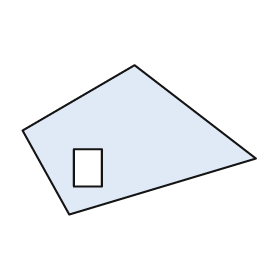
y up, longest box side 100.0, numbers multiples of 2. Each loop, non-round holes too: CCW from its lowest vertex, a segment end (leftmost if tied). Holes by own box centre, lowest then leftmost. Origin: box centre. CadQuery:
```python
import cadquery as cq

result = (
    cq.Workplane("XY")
    .moveTo(-30.0, -32.0)
    .lineTo(50.0, -8.0)
    .lineTo(-2.0, 32.0)
    .lineTo(-50.0, 4.0)
    .close()
    .moveTo(-28.0, -20.0)
    .lineTo(-16.0, -20.0)
    .lineTo(-16.0, -4.0)
    .lineTo(-28.0, -4.0)
    .close()
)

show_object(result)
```